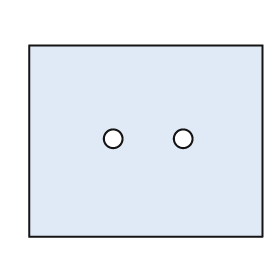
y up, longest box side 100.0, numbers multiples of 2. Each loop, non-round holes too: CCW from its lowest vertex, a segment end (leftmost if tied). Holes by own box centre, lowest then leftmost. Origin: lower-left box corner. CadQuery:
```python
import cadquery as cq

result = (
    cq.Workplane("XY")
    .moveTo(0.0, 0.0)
    .lineTo(100.0, 0.0)
    .lineTo(100.0, 82.0)
    .lineTo(0.0, 82.0)
    .close()
    .moveTo(36.0, 42.0)
    .circle(4.0)
    .moveTo(66.0, 42.0)
    .circle(4.0)
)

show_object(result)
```